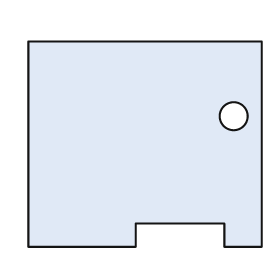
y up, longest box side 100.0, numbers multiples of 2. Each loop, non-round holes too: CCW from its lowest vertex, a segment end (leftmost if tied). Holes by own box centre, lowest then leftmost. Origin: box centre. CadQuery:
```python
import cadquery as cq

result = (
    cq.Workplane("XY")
    .moveTo(-50.0, -44.0)
    .lineTo(-4.0, -44.0)
    .lineTo(-4.0, -34.0)
    .lineTo(34.0, -34.0)
    .lineTo(34.0, -44.0)
    .lineTo(50.0, -44.0)
    .lineTo(50.0, 44.0)
    .lineTo(-50.0, 44.0)
    .close()
    .moveTo(38.0, 12.0)
    .circle(6.0)
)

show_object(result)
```